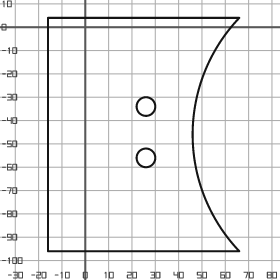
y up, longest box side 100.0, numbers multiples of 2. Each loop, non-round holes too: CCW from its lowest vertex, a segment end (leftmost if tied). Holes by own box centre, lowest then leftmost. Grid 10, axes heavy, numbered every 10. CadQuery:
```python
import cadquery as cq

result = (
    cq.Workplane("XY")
    .moveTo(-16.0, -96.0)
    .lineTo(66.0, -96.0)
    .threePointArc((46.0, -46.0), (66.0, 4.0))
    .lineTo(-16.0, 4.0)
    .close()
    .moveTo(26.0, -56.0)
    .circle(4.0)
    .moveTo(26.0, -34.0)
    .circle(4.0)
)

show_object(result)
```